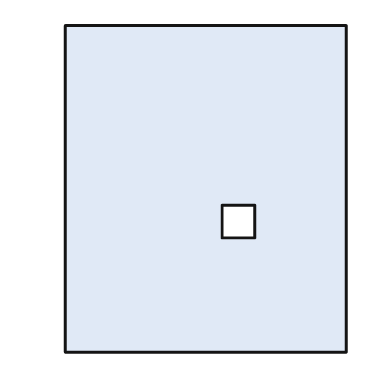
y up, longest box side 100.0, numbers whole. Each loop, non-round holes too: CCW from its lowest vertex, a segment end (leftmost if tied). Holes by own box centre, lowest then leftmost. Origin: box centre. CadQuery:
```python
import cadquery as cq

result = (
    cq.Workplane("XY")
    .moveTo(-43.0, -50.0)
    .lineTo(43.0, -50.0)
    .lineTo(43.0, 50.0)
    .lineTo(-43.0, 50.0)
    .close()
    .moveTo(5.0, -15.0)
    .lineTo(15.0, -15.0)
    .lineTo(15.0, -5.0)
    .lineTo(5.0, -5.0)
    .close()
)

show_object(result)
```